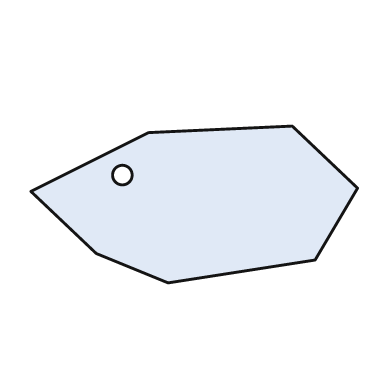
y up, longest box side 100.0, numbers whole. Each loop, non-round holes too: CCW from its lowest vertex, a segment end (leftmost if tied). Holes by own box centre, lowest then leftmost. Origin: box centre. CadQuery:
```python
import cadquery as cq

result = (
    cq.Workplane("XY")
    .moveTo(-8.0, -24.0)
    .lineTo(37.0, -17.0)
    .lineTo(50.0, 5.0)
    .lineTo(30.0, 24.0)
    .lineTo(-14.0, 22.0)
    .lineTo(-50.0, 4.0)
    .lineTo(-30.0, -15.0)
    .close()
    .moveTo(-22.0, 9.0)
    .circle(3.0)
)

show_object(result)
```